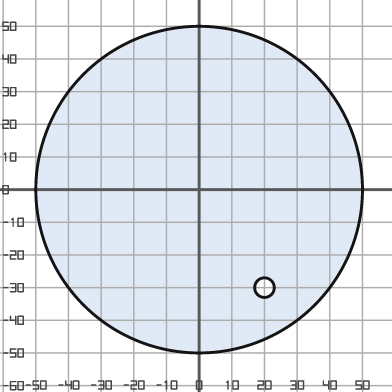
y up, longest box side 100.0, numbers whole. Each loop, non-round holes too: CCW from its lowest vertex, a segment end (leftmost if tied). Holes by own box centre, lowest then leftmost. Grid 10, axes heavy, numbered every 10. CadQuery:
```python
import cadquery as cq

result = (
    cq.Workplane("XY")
    .moveTo(0.0, 0.0)
    .circle(50.0)
    .moveTo(20.0, -30.0)
    .circle(3.0)
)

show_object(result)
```